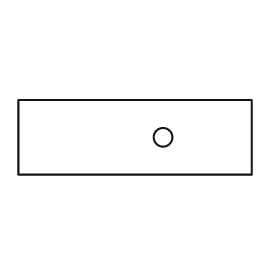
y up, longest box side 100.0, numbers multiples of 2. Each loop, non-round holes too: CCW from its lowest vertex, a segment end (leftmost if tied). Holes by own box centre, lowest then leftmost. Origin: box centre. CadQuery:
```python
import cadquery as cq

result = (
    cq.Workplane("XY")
    .moveTo(-50.0, -16.0)
    .lineTo(50.0, -16.0)
    .lineTo(50.0, 16.0)
    .lineTo(-50.0, 16.0)
    .close()
    .moveTo(12.0, 0.0)
    .circle(4.0)
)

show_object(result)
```